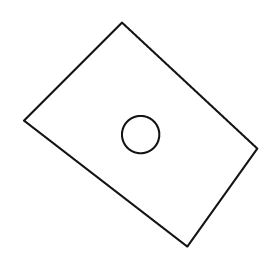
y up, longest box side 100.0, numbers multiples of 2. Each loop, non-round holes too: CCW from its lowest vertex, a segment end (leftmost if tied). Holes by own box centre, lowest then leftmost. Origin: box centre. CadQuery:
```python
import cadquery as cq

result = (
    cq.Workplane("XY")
    .moveTo(20.0, -48.0)
    .lineTo(50.0, -6.0)
    .lineTo(-8.0, 48.0)
    .lineTo(-50.0, 6.0)
    .close()
    .moveTo(0.0, 0.0)
    .circle(8.0)
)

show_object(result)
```